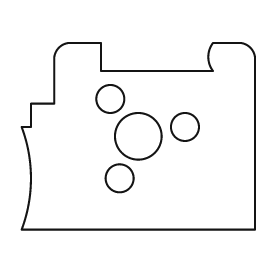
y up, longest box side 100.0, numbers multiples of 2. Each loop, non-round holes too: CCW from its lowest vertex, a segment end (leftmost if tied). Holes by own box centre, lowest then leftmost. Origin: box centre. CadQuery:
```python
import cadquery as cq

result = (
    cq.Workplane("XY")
    .moveTo(-50.0, -40.0)
    .lineTo(50.0, -40.0)
    .lineTo(50.0, 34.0)
    .threePointArc((48.0, 38.0), (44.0, 40.0))
    .lineTo(32.0, 40.0)
    .threePointArc((30.0, 34.0), (32.0, 28.0))
    .lineTo(-16.0, 28.0)
    .lineTo(-16.0, 40.0)
    .lineTo(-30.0, 40.0)
    .threePointArc((-34.0, 38.0), (-36.0, 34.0))
    .lineTo(-36.0, 14.0)
    .lineTo(-46.0, 14.0)
    .lineTo(-46.0, 4.0)
    .lineTo(-50.0, 4.0)
    .threePointArc((-46.0, -18.0), (-50.0, -40.0))
    .close()
    .moveTo(-8.0, -18.0)
    .circle(6.0)
    .moveTo(0.0, 0.0)
    .circle(10.0)
    .moveTo(20.0, 4.0)
    .circle(6.0)
    .moveTo(-12.0, 16.0)
    .circle(6.0)
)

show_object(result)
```